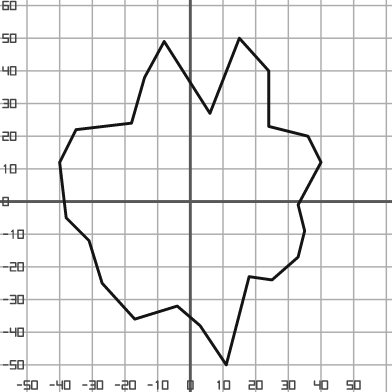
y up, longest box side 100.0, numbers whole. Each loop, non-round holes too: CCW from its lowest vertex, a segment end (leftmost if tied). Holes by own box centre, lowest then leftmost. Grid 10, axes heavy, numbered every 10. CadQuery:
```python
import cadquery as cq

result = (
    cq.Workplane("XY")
    .moveTo(11.0, -50.0)
    .lineTo(18.0, -23.0)
    .lineTo(25.0, -24.0)
    .lineTo(33.0, -17.0)
    .lineTo(35.0, -9.0)
    .lineTo(33.0, -1.0)
    .lineTo(40.0, 12.0)
    .lineTo(36.0, 20.0)
    .lineTo(24.0, 23.0)
    .lineTo(24.0, 40.0)
    .lineTo(15.0, 50.0)
    .lineTo(6.0, 27.0)
    .lineTo(-8.0, 49.0)
    .lineTo(-14.0, 38.0)
    .lineTo(-18.0, 24.0)
    .lineTo(-35.0, 22.0)
    .lineTo(-40.0, 12.0)
    .lineTo(-38.0, -5.0)
    .lineTo(-31.0, -12.0)
    .lineTo(-27.0, -25.0)
    .lineTo(-17.0, -36.0)
    .lineTo(-4.0, -32.0)
    .lineTo(3.0, -38.0)
    .close()
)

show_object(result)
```